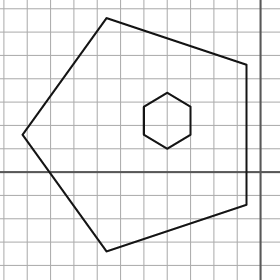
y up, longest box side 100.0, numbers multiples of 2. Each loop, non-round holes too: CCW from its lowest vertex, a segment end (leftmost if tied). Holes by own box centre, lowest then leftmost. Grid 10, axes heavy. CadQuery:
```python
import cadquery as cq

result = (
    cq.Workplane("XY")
    .moveTo(-66.0, -34.0)
    .lineTo(-6.0, -14.0)
    .lineTo(-6.0, 46.0)
    .lineTo(-66.0, 66.0)
    .lineTo(-102.0, 16.0)
    .close()
    .moveTo(-40.0, 10.0)
    .lineTo(-30.0, 16.0)
    .lineTo(-30.0, 28.0)
    .lineTo(-40.0, 34.0)
    .lineTo(-50.0, 28.0)
    .lineTo(-50.0, 16.0)
    .close()
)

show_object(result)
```